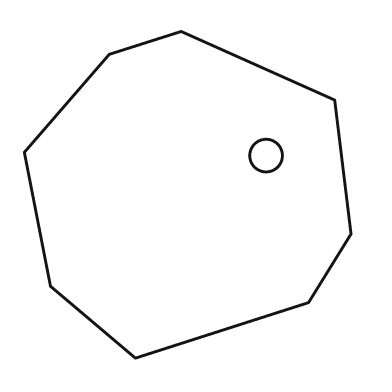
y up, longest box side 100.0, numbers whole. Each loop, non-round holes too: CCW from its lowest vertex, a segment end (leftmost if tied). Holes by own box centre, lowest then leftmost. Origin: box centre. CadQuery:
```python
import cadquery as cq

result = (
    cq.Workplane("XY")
    .moveTo(-16.0, -50.0)
    .lineTo(37.0, -33.0)
    .lineTo(50.0, -12.0)
    .lineTo(45.0, 29.0)
    .lineTo(-2.0, 50.0)
    .lineTo(-24.0, 43.0)
    .lineTo(-50.0, 13.0)
    .lineTo(-42.0, -28.0)
    .close()
    .moveTo(24.0, 12.0)
    .circle(5.0)
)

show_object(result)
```